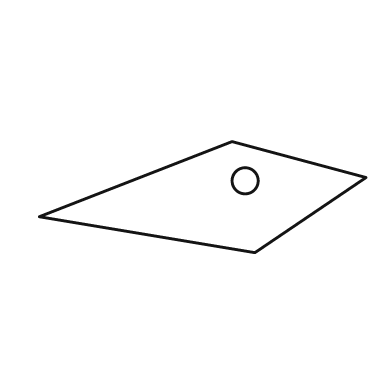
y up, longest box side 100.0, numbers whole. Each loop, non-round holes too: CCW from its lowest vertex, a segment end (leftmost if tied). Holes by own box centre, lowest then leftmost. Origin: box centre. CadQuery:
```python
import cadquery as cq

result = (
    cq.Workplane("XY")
    .moveTo(16.0, -17.0)
    .lineTo(50.0, 6.0)
    .lineTo(9.0, 17.0)
    .lineTo(-50.0, -6.0)
    .close()
    .moveTo(13.0, 5.0)
    .circle(4.0)
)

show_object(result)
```